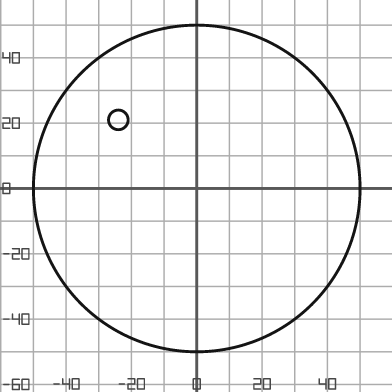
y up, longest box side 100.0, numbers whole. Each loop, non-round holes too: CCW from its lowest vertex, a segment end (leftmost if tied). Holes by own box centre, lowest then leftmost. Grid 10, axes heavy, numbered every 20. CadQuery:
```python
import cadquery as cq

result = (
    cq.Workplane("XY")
    .moveTo(0.0, 0.0)
    .circle(50.0)
    .moveTo(-24.0, 21.0)
    .circle(3.0)
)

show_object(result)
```